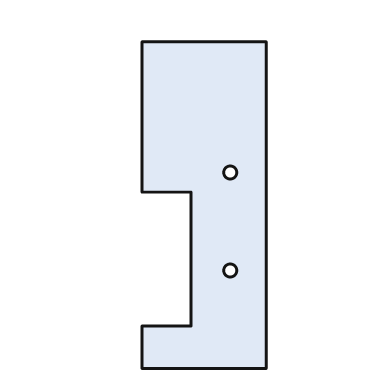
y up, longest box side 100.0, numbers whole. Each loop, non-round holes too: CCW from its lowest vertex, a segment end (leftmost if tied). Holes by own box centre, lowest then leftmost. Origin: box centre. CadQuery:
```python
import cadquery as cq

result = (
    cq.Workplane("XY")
    .moveTo(-19.0, -50.0)
    .lineTo(19.0, -50.0)
    .lineTo(19.0, 50.0)
    .lineTo(-19.0, 50.0)
    .lineTo(-19.0, 4.0)
    .lineTo(-4.0, 4.0)
    .lineTo(-4.0, -37.0)
    .lineTo(-19.0, -37.0)
    .close()
    .moveTo(8.0, -20.0)
    .circle(2.0)
    .moveTo(8.0, 10.0)
    .circle(2.0)
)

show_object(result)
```